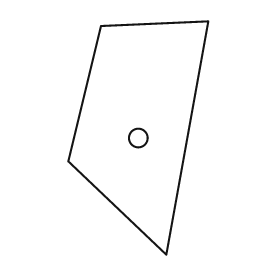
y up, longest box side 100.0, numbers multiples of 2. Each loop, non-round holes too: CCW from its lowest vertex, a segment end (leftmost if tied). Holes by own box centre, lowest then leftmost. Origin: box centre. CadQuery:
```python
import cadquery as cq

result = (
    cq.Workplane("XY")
    .moveTo(12.0, -50.0)
    .lineTo(30.0, 50.0)
    .lineTo(-16.0, 48.0)
    .lineTo(-30.0, -10.0)
    .close()
    .moveTo(0.0, 0.0)
    .circle(4.0)
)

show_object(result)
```